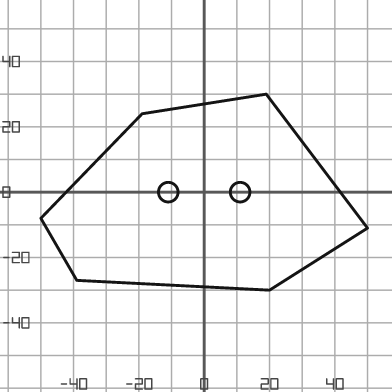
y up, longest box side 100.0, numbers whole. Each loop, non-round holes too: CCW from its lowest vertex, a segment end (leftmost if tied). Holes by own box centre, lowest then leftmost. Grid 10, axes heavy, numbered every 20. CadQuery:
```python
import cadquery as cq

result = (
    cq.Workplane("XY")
    .moveTo(20.0, -30.0)
    .lineTo(50.0, -11.0)
    .lineTo(19.0, 30.0)
    .lineTo(-19.0, 24.0)
    .lineTo(-50.0, -8.0)
    .lineTo(-39.0, -27.0)
    .close()
    .moveTo(-11.0, 0.0)
    .circle(3.0)
    .moveTo(11.0, 0.0)
    .circle(3.0)
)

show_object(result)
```